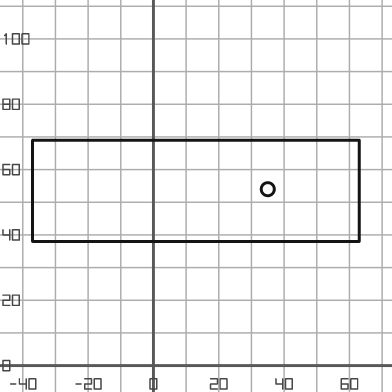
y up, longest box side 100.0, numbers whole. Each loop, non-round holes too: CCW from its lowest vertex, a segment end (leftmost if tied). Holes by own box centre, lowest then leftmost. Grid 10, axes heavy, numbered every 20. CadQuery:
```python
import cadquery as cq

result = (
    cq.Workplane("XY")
    .moveTo(-37.0, 38.0)
    .lineTo(63.0, 38.0)
    .lineTo(63.0, 69.0)
    .lineTo(-37.0, 69.0)
    .close()
    .moveTo(35.0, 54.0)
    .circle(2.0)
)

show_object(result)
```